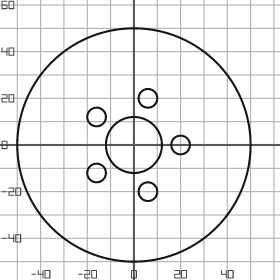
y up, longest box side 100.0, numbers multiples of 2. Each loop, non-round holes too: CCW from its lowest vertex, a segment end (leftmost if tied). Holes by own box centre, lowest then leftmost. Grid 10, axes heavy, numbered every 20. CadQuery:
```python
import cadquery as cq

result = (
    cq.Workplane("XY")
    .moveTo(0.0, 0.0)
    .circle(50.0)
    .moveTo(6.0, -20.0)
    .circle(4.0)
    .moveTo(-16.0, -12.0)
    .circle(4.0)
    .moveTo(0.0, 0.0)
    .circle(12.0)
    .moveTo(20.0, 0.0)
    .circle(4.0)
    .moveTo(-16.0, 12.0)
    .circle(4.0)
    .moveTo(6.0, 20.0)
    .circle(4.0)
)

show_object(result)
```